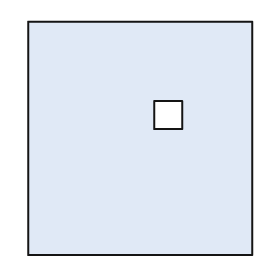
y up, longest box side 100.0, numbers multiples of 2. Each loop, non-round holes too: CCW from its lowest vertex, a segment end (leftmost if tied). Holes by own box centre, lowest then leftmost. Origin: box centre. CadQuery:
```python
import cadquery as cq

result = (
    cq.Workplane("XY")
    .moveTo(-48.0, -50.0)
    .lineTo(48.0, -50.0)
    .lineTo(48.0, 50.0)
    .lineTo(-48.0, 50.0)
    .close()
    .moveTo(6.0, 4.0)
    .lineTo(18.0, 4.0)
    .lineTo(18.0, 16.0)
    .lineTo(6.0, 16.0)
    .close()
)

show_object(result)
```